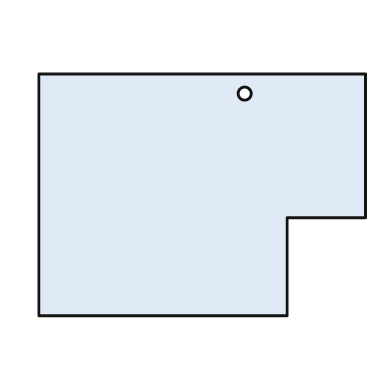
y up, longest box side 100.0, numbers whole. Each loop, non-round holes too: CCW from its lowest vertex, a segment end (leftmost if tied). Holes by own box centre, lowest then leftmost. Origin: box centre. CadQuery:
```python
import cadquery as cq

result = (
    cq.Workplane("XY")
    .moveTo(-50.0, -37.0)
    .lineTo(26.0, -37.0)
    .lineTo(26.0, -7.0)
    .lineTo(50.0, -7.0)
    .lineTo(50.0, 37.0)
    .lineTo(-50.0, 37.0)
    .close()
    .moveTo(13.0, 31.0)
    .circle(2.0)
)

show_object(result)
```